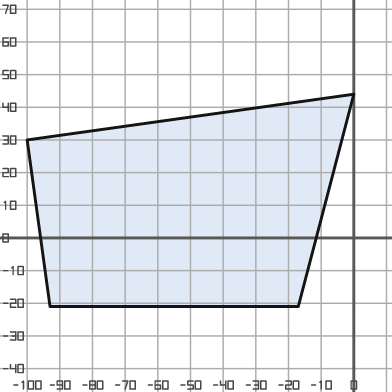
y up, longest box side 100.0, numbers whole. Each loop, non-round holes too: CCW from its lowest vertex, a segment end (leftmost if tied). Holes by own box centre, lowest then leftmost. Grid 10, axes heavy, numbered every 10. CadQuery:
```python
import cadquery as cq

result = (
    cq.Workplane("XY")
    .moveTo(-93.0, -21.0)
    .lineTo(-17.0, -21.0)
    .lineTo(0.0, 44.0)
    .lineTo(-100.0, 30.0)
    .close()
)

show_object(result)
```